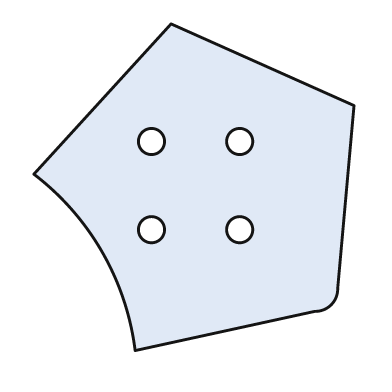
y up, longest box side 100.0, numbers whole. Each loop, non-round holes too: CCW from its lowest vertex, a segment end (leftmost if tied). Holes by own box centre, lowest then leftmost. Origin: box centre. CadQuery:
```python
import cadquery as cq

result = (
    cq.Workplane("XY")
    .moveTo(-18.0, -50.0)
    .lineTo(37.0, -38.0)
    .threePointArc((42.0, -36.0), (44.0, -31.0))
    .lineTo(49.0, 25.0)
    .lineTo(-7.0, 50.0)
    .lineTo(-49.0, 4.0)
    .threePointArc((-28.0, -20.0), (-18.0, -50.0))
    .close()
    .moveTo(-13.0, -13.0)
    .circle(4.0)
    .moveTo(14.0, -13.0)
    .circle(4.0)
    .moveTo(-13.0, 14.0)
    .circle(4.0)
    .moveTo(14.0, 14.0)
    .circle(4.0)
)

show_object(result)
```